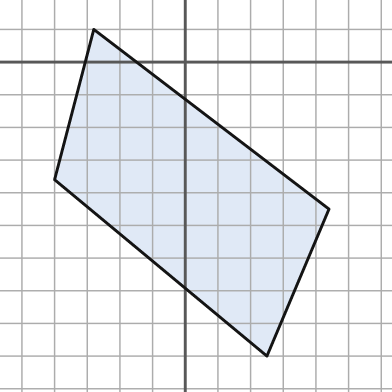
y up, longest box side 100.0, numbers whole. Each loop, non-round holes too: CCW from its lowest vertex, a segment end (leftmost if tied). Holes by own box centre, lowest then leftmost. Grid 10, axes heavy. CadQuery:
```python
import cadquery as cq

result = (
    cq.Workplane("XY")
    .moveTo(25.0, -90.0)
    .lineTo(44.0, -45.0)
    .lineTo(-28.0, 10.0)
    .lineTo(-40.0, -36.0)
    .close()
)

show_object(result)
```